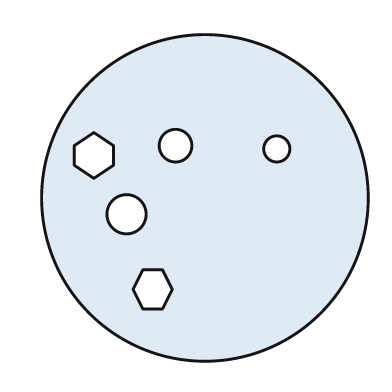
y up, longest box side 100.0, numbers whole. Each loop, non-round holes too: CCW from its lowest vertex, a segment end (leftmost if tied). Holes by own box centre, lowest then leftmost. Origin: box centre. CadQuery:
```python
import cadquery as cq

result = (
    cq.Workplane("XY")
    .moveTo(0.0, 0.0)
    .circle(50.0)
    .moveTo(-19.0, -34.0)
    .lineTo(-13.0, -34.0)
    .lineTo(-10.0, -28.0)
    .lineTo(-13.0, -22.0)
    .lineTo(-19.0, -22.0)
    .lineTo(-22.0, -28.0)
    .close()
    .moveTo(-24.0, -5.0)
    .circle(6.0)
    .moveTo(-34.0, 6.0)
    .lineTo(-28.0, 10.0)
    .lineTo(-28.0, 16.0)
    .lineTo(-34.0, 20.0)
    .lineTo(-40.0, 16.0)
    .lineTo(-40.0, 10.0)
    .close()
    .moveTo(22.0, 15.0)
    .circle(4.0)
    .moveTo(-9.0, 16.0)
    .circle(5.0)
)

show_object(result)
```